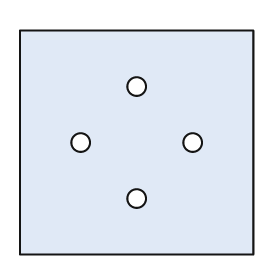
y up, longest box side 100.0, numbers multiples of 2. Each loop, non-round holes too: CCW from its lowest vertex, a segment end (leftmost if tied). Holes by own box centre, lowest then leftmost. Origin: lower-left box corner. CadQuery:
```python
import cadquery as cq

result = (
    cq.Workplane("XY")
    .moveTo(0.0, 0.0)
    .lineTo(100.0, 0.0)
    .lineTo(100.0, 96.0)
    .lineTo(0.0, 96.0)
    .close()
    .moveTo(50.0, 24.0)
    .circle(4.0)
    .moveTo(26.0, 48.0)
    .circle(4.0)
    .moveTo(74.0, 48.0)
    .circle(4.0)
    .moveTo(50.0, 72.0)
    .circle(4.0)
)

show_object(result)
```